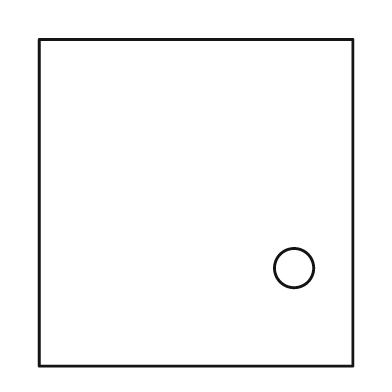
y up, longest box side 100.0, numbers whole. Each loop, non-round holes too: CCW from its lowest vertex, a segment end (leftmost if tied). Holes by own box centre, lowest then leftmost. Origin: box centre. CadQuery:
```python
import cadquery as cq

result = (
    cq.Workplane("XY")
    .moveTo(-48.0, -50.0)
    .lineTo(48.0, -50.0)
    .lineTo(48.0, 50.0)
    .lineTo(-48.0, 50.0)
    .close()
    .moveTo(30.0, -20.0)
    .circle(6.0)
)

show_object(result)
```